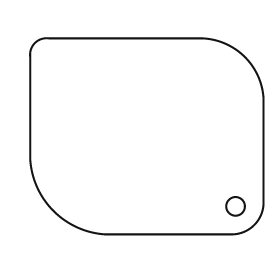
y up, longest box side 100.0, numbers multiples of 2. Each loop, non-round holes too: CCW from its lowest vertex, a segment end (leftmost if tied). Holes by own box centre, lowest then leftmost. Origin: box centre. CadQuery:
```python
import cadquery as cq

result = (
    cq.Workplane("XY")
    .moveTo(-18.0, -42.0)
    .lineTo(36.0, -42.0)
    .threePointArc((46.0, -38.0), (50.0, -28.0))
    .lineTo(50.0, 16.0)
    .threePointArc((42.0, 34.0), (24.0, 42.0))
    .lineTo(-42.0, 42.0)
    .threePointArc((-48.0, 40.0), (-50.0, 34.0))
    .lineTo(-50.0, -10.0)
    .threePointArc((-40.0, -32.0), (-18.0, -42.0))
    .close()
    .moveTo(38.0, -30.0)
    .circle(4.0)
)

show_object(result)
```